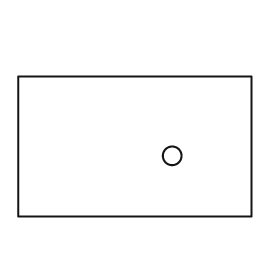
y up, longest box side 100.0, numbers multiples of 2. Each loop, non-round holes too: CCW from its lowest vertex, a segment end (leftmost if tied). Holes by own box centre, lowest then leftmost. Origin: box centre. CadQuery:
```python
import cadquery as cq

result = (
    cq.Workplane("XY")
    .moveTo(-50.0, -30.0)
    .lineTo(50.0, -30.0)
    .lineTo(50.0, 30.0)
    .lineTo(-50.0, 30.0)
    .close()
    .moveTo(16.0, -4.0)
    .circle(4.0)
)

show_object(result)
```